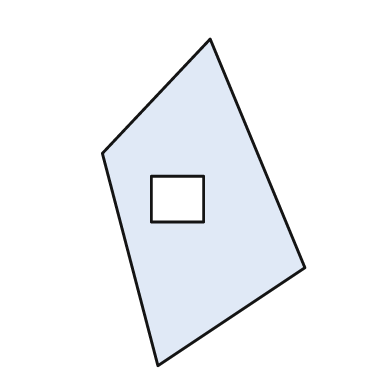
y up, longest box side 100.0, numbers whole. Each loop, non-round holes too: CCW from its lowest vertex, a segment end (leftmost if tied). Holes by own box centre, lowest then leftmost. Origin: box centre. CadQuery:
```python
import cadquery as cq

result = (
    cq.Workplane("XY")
    .moveTo(-14.0, -50.0)
    .lineTo(31.0, -20.0)
    .lineTo(2.0, 50.0)
    .lineTo(-31.0, 15.0)
    .close()
    .moveTo(-16.0, -6.0)
    .lineTo(0.0, -6.0)
    .lineTo(0.0, 8.0)
    .lineTo(-16.0, 8.0)
    .close()
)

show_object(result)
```